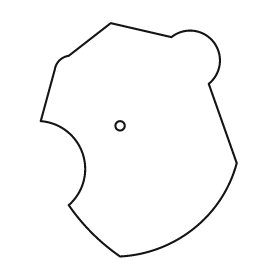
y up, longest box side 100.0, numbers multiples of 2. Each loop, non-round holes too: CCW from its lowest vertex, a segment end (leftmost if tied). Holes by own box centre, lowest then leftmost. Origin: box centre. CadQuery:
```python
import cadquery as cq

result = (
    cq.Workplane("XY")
    .moveTo(-8.0, -50.0)
    .threePointArc((10.0, -46.0), (26.0, -36.0))
    .threePointArc((36.0, -24.0), (42.0, -10.0))
    .lineTo(30.0, 24.0)
    .threePointArc((32.0, 42.0), (14.0, 44.0))
    .lineTo(-12.0, 50.0)
    .lineTo(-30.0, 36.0)
    .threePointArc((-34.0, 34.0), (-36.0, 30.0))
    .lineTo(-42.0, 8.0)
    .threePointArc((-24.0, -6.0), (-30.0, -28.0))
    .threePointArc((-20.0, -40.0), (-8.0, -50.0))
    .close()
    .moveTo(-8.0, 6.0)
    .circle(2.0)
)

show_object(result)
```